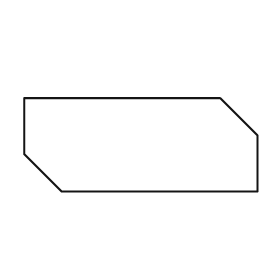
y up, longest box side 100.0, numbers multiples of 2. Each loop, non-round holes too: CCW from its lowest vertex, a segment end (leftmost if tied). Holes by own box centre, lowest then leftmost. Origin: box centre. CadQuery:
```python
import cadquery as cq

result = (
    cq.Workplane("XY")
    .moveTo(-34.0, -20.0)
    .lineTo(50.0, -20.0)
    .lineTo(50.0, 4.0)
    .lineTo(34.0, 20.0)
    .lineTo(-50.0, 20.0)
    .lineTo(-50.0, -4.0)
    .close()
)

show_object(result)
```